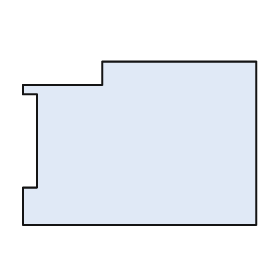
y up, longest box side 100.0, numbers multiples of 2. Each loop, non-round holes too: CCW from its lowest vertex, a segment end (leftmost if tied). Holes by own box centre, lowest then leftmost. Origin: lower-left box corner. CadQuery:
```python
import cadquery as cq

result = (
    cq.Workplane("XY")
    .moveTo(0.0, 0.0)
    .lineTo(100.0, 0.0)
    .lineTo(100.0, 70.0)
    .lineTo(34.0, 70.0)
    .lineTo(34.0, 60.0)
    .lineTo(0.0, 60.0)
    .lineTo(0.0, 56.0)
    .lineTo(6.0, 56.0)
    .lineTo(6.0, 16.0)
    .lineTo(0.0, 16.0)
    .close()
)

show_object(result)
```